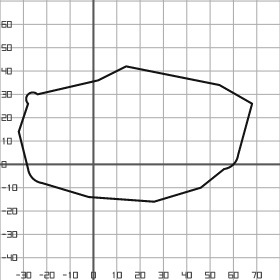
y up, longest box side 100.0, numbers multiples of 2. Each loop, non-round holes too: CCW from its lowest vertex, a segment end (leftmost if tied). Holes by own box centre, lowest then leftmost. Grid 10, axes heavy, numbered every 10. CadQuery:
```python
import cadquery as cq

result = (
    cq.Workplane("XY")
    .moveTo(26.0, -16.0)
    .lineTo(46.0, -10.0)
    .lineTo(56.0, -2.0)
    .threePointArc((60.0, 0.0), (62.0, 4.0))
    .lineTo(68.0, 26.0)
    .lineTo(54.0, 34.0)
    .lineTo(14.0, 42.0)
    .lineTo(2.0, 36.0)
    .lineTo(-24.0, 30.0)
    .threePointArc((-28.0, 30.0), (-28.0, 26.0))
    .lineTo(-32.0, 14.0)
    .lineTo(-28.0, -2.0)
    .threePointArc((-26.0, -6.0), (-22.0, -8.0))
    .lineTo(-2.0, -14.0)
    .close()
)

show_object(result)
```